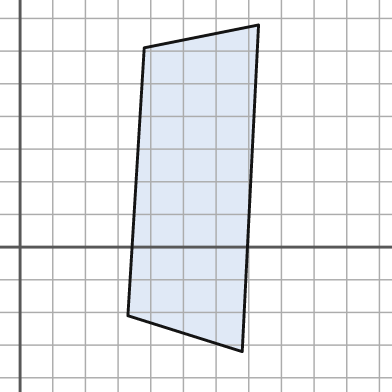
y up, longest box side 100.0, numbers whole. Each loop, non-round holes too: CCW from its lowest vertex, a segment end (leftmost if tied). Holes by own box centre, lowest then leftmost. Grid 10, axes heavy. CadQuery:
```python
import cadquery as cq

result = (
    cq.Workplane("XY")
    .moveTo(68.0, -32.0)
    .lineTo(73.0, 68.0)
    .lineTo(38.0, 61.0)
    .lineTo(33.0, -21.0)
    .close()
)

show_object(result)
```